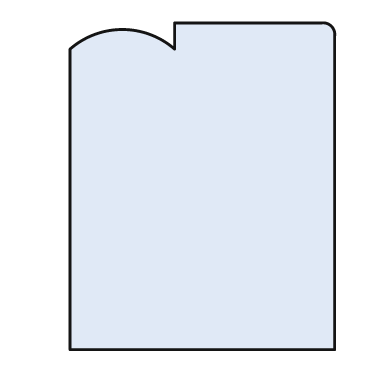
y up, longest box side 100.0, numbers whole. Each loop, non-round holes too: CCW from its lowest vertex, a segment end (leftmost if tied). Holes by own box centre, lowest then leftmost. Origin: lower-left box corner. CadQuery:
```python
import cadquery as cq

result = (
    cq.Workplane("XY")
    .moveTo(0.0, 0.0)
    .lineTo(81.0, 0.0)
    .lineTo(81.0, 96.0)
    .threePointArc((80.0, 99.0), (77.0, 100.0))
    .lineTo(32.0, 100.0)
    .lineTo(32.0, 92.0)
    .threePointArc((16.0, 98.0), (0.0, 92.0))
    .close()
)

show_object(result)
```